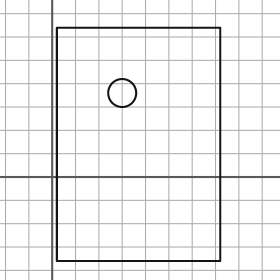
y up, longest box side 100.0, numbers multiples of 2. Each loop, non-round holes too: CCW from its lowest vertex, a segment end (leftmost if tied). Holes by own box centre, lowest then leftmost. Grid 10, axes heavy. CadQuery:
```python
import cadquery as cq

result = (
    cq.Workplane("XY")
    .moveTo(2.0, -36.0)
    .lineTo(72.0, -36.0)
    .lineTo(72.0, 64.0)
    .lineTo(2.0, 64.0)
    .close()
    .moveTo(30.0, 36.0)
    .circle(6.0)
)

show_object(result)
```